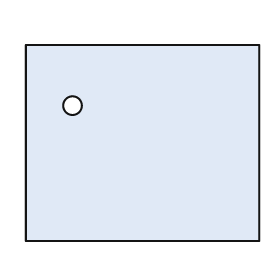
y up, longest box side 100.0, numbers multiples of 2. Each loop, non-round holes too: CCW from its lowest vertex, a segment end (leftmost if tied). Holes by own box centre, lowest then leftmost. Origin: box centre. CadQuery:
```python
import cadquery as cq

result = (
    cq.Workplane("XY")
    .moveTo(-50.0, -42.0)
    .lineTo(50.0, -42.0)
    .lineTo(50.0, 42.0)
    .lineTo(-50.0, 42.0)
    .close()
    .moveTo(-30.0, 16.0)
    .circle(4.0)
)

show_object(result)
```